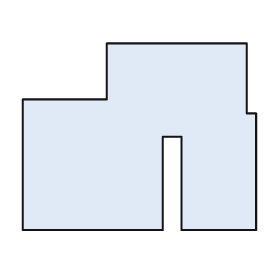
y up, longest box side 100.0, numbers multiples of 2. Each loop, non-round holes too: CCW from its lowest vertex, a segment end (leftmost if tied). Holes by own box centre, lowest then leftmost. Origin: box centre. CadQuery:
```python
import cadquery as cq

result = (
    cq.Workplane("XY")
    .moveTo(-50.0, -40.0)
    .lineTo(10.0, -40.0)
    .lineTo(10.0, 0.0)
    .lineTo(18.0, 0.0)
    .lineTo(18.0, -40.0)
    .lineTo(50.0, -40.0)
    .lineTo(50.0, 10.0)
    .lineTo(46.0, 10.0)
    .lineTo(46.0, 40.0)
    .lineTo(-14.0, 40.0)
    .lineTo(-14.0, 16.0)
    .lineTo(-50.0, 16.0)
    .close()
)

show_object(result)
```